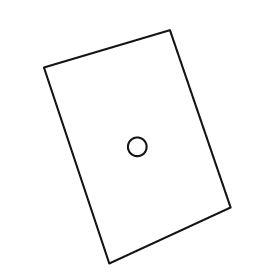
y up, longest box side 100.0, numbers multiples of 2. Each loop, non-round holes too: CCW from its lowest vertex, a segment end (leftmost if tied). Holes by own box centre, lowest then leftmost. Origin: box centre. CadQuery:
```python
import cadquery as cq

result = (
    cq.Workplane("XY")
    .moveTo(-12.0, -50.0)
    .lineTo(40.0, -26.0)
    .lineTo(14.0, 50.0)
    .lineTo(-40.0, 34.0)
    .close()
    .moveTo(0.0, 0.0)
    .circle(4.0)
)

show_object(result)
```